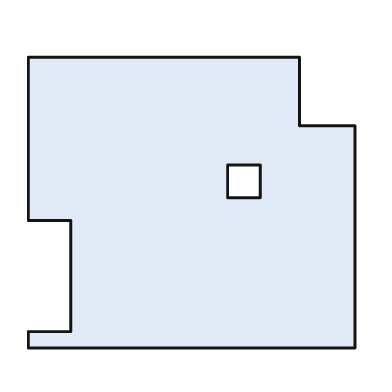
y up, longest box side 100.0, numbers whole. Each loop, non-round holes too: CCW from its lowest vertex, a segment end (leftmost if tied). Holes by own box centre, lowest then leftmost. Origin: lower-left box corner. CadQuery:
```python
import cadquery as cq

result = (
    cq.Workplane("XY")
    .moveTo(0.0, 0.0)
    .lineTo(100.0, 0.0)
    .lineTo(100.0, 68.0)
    .lineTo(83.0, 68.0)
    .lineTo(83.0, 89.0)
    .lineTo(0.0, 89.0)
    .lineTo(0.0, 39.0)
    .lineTo(13.0, 39.0)
    .lineTo(13.0, 5.0)
    .lineTo(0.0, 5.0)
    .close()
    .moveTo(61.0, 46.0)
    .lineTo(71.0, 46.0)
    .lineTo(71.0, 56.0)
    .lineTo(61.0, 56.0)
    .close()
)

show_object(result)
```